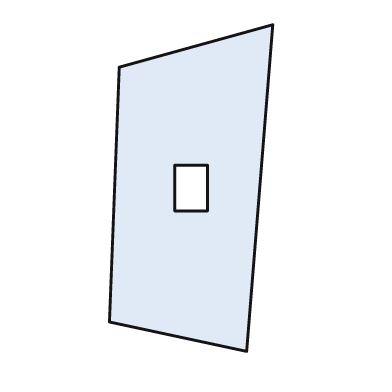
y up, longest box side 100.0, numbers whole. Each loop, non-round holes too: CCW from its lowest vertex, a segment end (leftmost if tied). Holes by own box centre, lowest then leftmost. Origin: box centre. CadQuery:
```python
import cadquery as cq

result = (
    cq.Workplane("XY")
    .moveTo(17.0, -50.0)
    .lineTo(25.0, 50.0)
    .lineTo(-22.0, 37.0)
    .lineTo(-25.0, -41.0)
    .close()
    .moveTo(-5.0, -7.0)
    .lineTo(5.0, -7.0)
    .lineTo(5.0, 7.0)
    .lineTo(-5.0, 7.0)
    .close()
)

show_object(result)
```